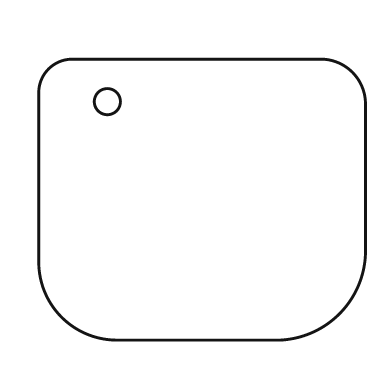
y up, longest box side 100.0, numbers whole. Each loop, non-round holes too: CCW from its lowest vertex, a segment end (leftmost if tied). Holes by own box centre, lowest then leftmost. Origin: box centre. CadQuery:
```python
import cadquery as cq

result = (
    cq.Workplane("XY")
    .moveTo(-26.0, -43.0)
    .lineTo(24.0, -43.0)
    .threePointArc((42.0, -35.0), (50.0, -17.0))
    .lineTo(50.0, 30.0)
    .threePointArc((46.0, 39.0), (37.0, 43.0))
    .lineTo(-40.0, 43.0)
    .threePointArc((-47.0, 40.0), (-50.0, 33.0))
    .lineTo(-50.0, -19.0)
    .threePointArc((-43.0, -36.0), (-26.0, -43.0))
    .close()
    .moveTo(-29.0, 30.0)
    .circle(4.0)
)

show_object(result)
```